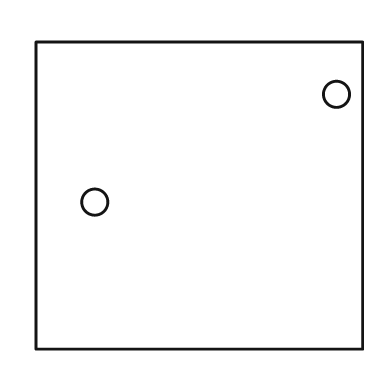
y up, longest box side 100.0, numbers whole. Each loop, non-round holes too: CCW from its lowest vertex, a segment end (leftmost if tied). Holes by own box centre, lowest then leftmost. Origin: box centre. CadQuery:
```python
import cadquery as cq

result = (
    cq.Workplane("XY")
    .moveTo(-50.0, -47.0)
    .lineTo(50.0, -47.0)
    .lineTo(50.0, 47.0)
    .lineTo(-50.0, 47.0)
    .close()
    .moveTo(-32.0, -2.0)
    .circle(4.0)
    .moveTo(42.0, 31.0)
    .circle(4.0)
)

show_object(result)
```